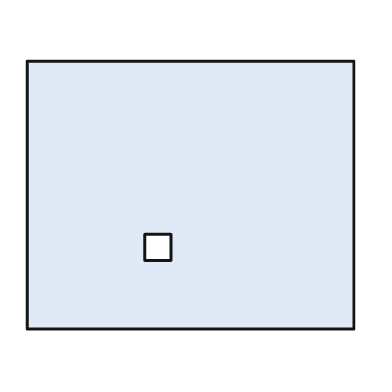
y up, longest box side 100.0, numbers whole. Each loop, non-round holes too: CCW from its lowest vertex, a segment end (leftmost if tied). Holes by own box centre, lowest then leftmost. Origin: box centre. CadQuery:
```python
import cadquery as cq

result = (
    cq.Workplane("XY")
    .moveTo(-50.0, -41.0)
    .lineTo(50.0, -41.0)
    .lineTo(50.0, 41.0)
    .lineTo(-50.0, 41.0)
    .close()
    .moveTo(-14.0, -20.0)
    .lineTo(-6.0, -20.0)
    .lineTo(-6.0, -12.0)
    .lineTo(-14.0, -12.0)
    .close()
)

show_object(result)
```